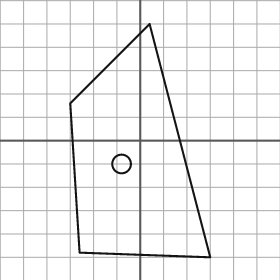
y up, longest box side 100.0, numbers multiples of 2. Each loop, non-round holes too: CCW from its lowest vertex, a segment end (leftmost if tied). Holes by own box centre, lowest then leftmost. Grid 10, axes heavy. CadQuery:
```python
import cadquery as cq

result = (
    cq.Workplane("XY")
    .moveTo(30.0, -50.0)
    .lineTo(4.0, 50.0)
    .lineTo(-30.0, 16.0)
    .lineTo(-26.0, -48.0)
    .close()
    .moveTo(-8.0, -10.0)
    .circle(4.0)
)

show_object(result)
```